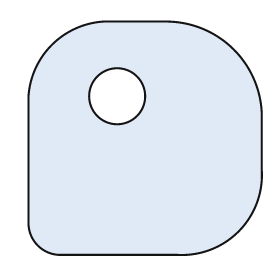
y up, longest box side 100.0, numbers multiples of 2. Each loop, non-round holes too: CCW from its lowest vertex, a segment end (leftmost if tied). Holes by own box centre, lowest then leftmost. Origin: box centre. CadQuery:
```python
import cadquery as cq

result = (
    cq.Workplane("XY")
    .moveTo(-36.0, -50.0)
    .lineTo(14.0, -50.0)
    .threePointArc((40.0, -40.0), (50.0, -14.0))
    .lineTo(50.0, 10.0)
    .threePointArc((38.0, 38.0), (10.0, 50.0))
    .lineTo(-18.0, 50.0)
    .threePointArc((-40.0, 40.0), (-50.0, 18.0))
    .lineTo(-50.0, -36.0)
    .threePointArc((-46.0, -46.0), (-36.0, -50.0))
    .close()
    .moveTo(-12.0, 18.0)
    .circle(12.0)
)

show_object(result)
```